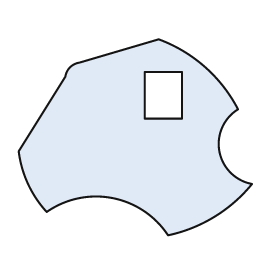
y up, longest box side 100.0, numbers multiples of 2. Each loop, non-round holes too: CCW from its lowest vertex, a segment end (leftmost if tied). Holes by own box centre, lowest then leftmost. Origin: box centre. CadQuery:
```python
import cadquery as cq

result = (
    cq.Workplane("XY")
    .moveTo(14.0, -42.0)
    .threePointArc((34.0, -34.0), (50.0, -20.0))
    .threePointArc((36.0, -6.0), (44.0, 12.0))
    .threePointArc((30.0, 30.0), (10.0, 42.0))
    .lineTo(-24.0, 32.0)
    .threePointArc((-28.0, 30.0), (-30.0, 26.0))
    .lineTo(-50.0, -6.0)
    .threePointArc((-46.0, -20.0), (-38.0, -32.0))
    .threePointArc((-10.0, -26.0), (14.0, -42.0))
    .close()
    .moveTo(4.0, 8.0)
    .lineTo(20.0, 8.0)
    .lineTo(20.0, 28.0)
    .lineTo(4.0, 28.0)
    .close()
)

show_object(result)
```